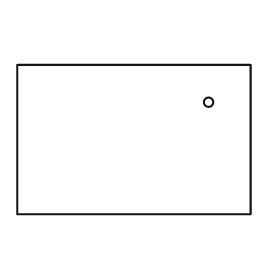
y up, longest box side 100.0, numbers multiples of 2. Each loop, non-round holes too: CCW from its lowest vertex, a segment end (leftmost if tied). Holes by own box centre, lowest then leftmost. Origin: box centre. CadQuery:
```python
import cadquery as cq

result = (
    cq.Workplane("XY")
    .moveTo(-50.0, -32.0)
    .lineTo(50.0, -32.0)
    .lineTo(50.0, 32.0)
    .lineTo(-50.0, 32.0)
    .close()
    .moveTo(32.0, 16.0)
    .circle(2.0)
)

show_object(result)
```